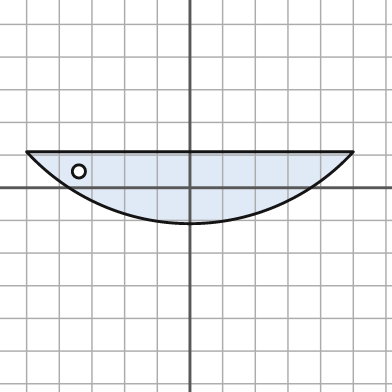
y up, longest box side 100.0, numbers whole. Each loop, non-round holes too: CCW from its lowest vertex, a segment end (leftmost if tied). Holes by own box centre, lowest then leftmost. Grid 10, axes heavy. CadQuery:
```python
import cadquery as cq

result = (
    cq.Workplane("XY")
    .moveTo(-50.0, 11.0)
    .threePointArc((0.0, -11.0), (50.0, 11.0))
    .close()
    .moveTo(-34.0, 5.0)
    .circle(2.0)
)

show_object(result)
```